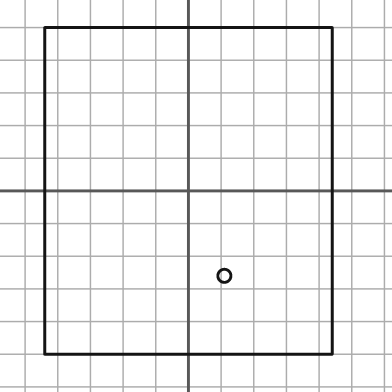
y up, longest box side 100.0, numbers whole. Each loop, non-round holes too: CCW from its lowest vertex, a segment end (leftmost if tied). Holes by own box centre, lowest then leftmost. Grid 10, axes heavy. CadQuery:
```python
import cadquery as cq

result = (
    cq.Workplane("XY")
    .moveTo(-44.0, -50.0)
    .lineTo(44.0, -50.0)
    .lineTo(44.0, 50.0)
    .lineTo(-44.0, 50.0)
    .close()
    .moveTo(11.0, -26.0)
    .circle(2.0)
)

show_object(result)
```